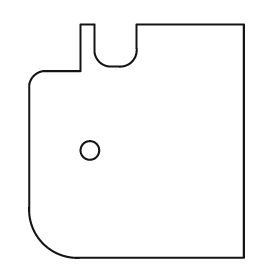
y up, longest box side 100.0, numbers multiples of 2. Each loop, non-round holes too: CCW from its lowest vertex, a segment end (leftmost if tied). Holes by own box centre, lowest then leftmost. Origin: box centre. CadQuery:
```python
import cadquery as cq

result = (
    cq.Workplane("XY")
    .moveTo(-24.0, -50.0)
    .lineTo(46.0, -50.0)
    .lineTo(46.0, 50.0)
    .lineTo(0.0, 50.0)
    .lineTo(0.0, 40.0)
    .threePointArc((-2.0, 34.0), (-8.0, 32.0))
    .lineTo(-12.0, 32.0)
    .threePointArc((-16.0, 34.0), (-18.0, 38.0))
    .lineTo(-18.0, 50.0)
    .lineTo(-24.0, 50.0)
    .lineTo(-24.0, 30.0)
    .lineTo(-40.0, 30.0)
    .threePointArc((-44.0, 28.0), (-46.0, 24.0))
    .lineTo(-46.0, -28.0)
    .threePointArc((-40.0, -44.0), (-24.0, -50.0))
    .close()
    .moveTo(-20.0, -4.0)
    .circle(4.0)
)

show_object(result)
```